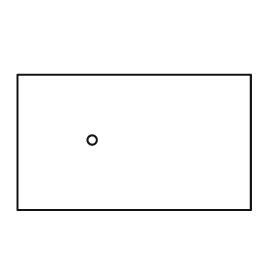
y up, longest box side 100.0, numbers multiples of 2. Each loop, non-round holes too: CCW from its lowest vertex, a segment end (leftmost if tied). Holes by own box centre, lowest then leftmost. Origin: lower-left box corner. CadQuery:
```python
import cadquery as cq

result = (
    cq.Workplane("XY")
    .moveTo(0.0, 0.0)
    .lineTo(100.0, 0.0)
    .lineTo(100.0, 58.0)
    .lineTo(0.0, 58.0)
    .close()
    .moveTo(32.0, 30.0)
    .circle(2.0)
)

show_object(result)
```